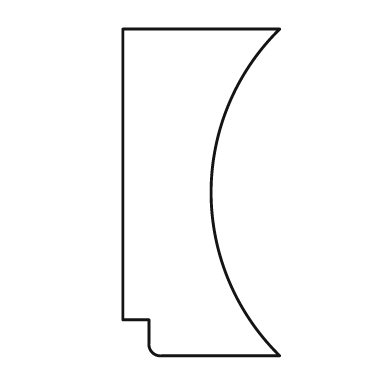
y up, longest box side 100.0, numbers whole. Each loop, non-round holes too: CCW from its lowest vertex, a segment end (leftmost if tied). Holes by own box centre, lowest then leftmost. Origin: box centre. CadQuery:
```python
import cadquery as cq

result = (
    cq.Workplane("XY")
    .moveTo(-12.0, -50.0)
    .lineTo(24.0, -50.0)
    .threePointArc((3.0, 0.0), (24.0, 50.0))
    .lineTo(-24.0, 50.0)
    .lineTo(-24.0, -39.0)
    .lineTo(-16.0, -39.0)
    .lineTo(-16.0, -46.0)
    .threePointArc((-15.0, -49.0), (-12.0, -50.0))
    .close()
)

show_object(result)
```